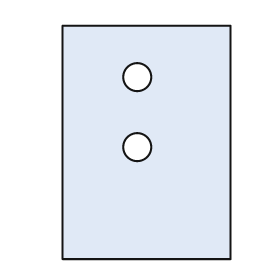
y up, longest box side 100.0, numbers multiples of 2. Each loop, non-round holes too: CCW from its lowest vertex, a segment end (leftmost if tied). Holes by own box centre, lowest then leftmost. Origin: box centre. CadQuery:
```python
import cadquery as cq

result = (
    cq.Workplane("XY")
    .moveTo(-36.0, -50.0)
    .lineTo(36.0, -50.0)
    .lineTo(36.0, 50.0)
    .lineTo(-36.0, 50.0)
    .close()
    .moveTo(-4.0, -2.0)
    .circle(6.0)
    .moveTo(-4.0, 28.0)
    .circle(6.0)
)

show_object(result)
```